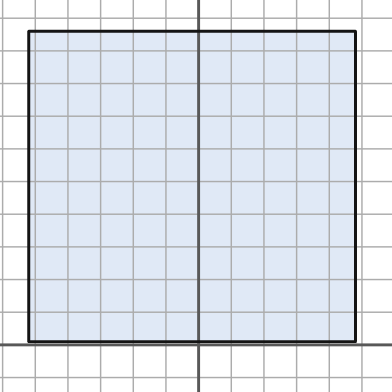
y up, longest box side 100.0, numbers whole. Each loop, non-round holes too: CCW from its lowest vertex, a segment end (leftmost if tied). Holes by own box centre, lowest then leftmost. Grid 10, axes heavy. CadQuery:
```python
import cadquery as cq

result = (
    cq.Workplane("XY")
    .moveTo(-52.0, 1.0)
    .lineTo(48.0, 1.0)
    .lineTo(48.0, 96.0)
    .lineTo(-52.0, 96.0)
    .close()
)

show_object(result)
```